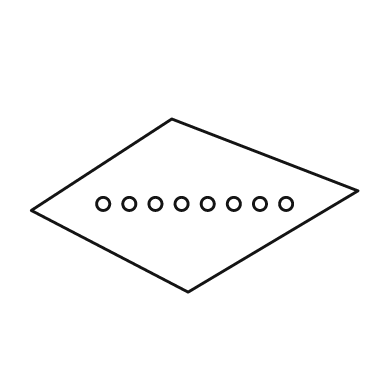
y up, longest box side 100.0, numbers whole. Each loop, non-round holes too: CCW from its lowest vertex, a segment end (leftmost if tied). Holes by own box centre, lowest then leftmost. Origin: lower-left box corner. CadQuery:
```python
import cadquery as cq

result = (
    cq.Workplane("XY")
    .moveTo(48.0, 0.0)
    .lineTo(100.0, 31.0)
    .lineTo(43.0, 53.0)
    .lineTo(0.0, 25.0)
    .close()
    .moveTo(22.0, 27.0)
    .circle(2.0)
    .moveTo(30.0, 27.0)
    .circle(2.0)
    .moveTo(38.0, 27.0)
    .circle(2.0)
    .moveTo(46.0, 27.0)
    .circle(2.0)
    .moveTo(54.0, 27.0)
    .circle(2.0)
    .moveTo(62.0, 27.0)
    .circle(2.0)
    .moveTo(70.0, 27.0)
    .circle(2.0)
    .moveTo(78.0, 27.0)
    .circle(2.0)
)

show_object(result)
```